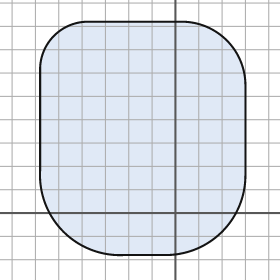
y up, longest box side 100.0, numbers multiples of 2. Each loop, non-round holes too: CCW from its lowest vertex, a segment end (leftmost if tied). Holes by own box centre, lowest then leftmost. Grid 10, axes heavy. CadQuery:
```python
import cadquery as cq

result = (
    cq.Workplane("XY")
    .moveTo(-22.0, -18.0)
    .lineTo(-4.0, -18.0)
    .threePointArc((20.0, -8.0), (30.0, 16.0))
    .lineTo(30.0, 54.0)
    .threePointArc((22.0, 74.0), (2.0, 82.0))
    .lineTo(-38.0, 82.0)
    .threePointArc((-52.0, 76.0), (-58.0, 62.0))
    .lineTo(-58.0, 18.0)
    .threePointArc((-48.0, -8.0), (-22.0, -18.0))
    .close()
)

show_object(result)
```